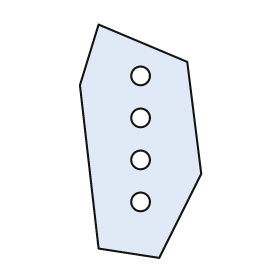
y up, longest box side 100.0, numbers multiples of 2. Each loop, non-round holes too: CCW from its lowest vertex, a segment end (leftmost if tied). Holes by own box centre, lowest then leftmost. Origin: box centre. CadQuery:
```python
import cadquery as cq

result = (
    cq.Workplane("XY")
    .moveTo(8.0, -50.0)
    .lineTo(26.0, -14.0)
    .lineTo(20.0, 34.0)
    .lineTo(-18.0, 50.0)
    .lineTo(-26.0, 24.0)
    .lineTo(-18.0, -46.0)
    .close()
    .moveTo(0.0, -26.0)
    .circle(4.0)
    .moveTo(0.0, -8.0)
    .circle(4.0)
    .moveTo(0.0, 10.0)
    .circle(4.0)
    .moveTo(0.0, 28.0)
    .circle(4.0)
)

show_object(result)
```